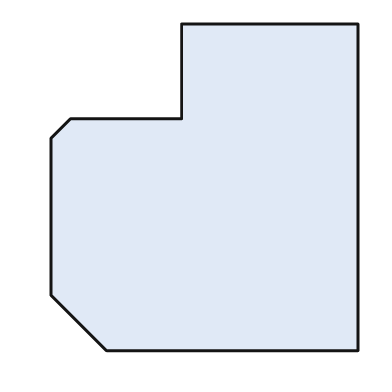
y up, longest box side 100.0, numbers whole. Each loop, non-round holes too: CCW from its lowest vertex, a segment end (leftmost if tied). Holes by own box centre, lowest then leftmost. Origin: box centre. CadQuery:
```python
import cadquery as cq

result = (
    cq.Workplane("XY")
    .moveTo(-30.0, -50.0)
    .lineTo(47.0, -50.0)
    .lineTo(47.0, 50.0)
    .lineTo(-7.0, 50.0)
    .lineTo(-7.0, 21.0)
    .lineTo(-41.0, 21.0)
    .lineTo(-47.0, 15.0)
    .lineTo(-47.0, -33.0)
    .close()
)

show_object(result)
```